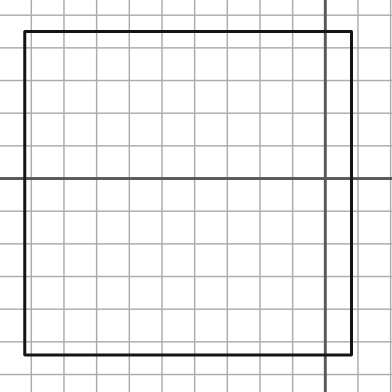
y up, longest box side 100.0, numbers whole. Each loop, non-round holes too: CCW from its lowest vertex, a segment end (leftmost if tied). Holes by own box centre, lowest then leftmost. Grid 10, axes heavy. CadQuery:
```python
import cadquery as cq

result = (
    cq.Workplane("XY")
    .moveTo(-92.0, -54.0)
    .lineTo(8.0, -54.0)
    .lineTo(8.0, 45.0)
    .lineTo(-92.0, 45.0)
    .close()
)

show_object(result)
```